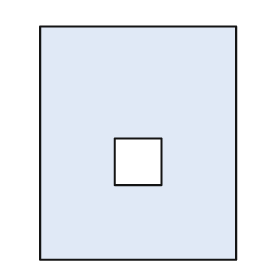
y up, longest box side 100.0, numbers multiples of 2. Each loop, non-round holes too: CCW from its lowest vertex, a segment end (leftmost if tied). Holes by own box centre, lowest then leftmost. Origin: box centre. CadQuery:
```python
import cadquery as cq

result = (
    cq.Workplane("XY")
    .moveTo(-42.0, -50.0)
    .lineTo(42.0, -50.0)
    .lineTo(42.0, 50.0)
    .lineTo(-42.0, 50.0)
    .close()
    .moveTo(-10.0, -18.0)
    .lineTo(10.0, -18.0)
    .lineTo(10.0, 2.0)
    .lineTo(-10.0, 2.0)
    .close()
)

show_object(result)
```